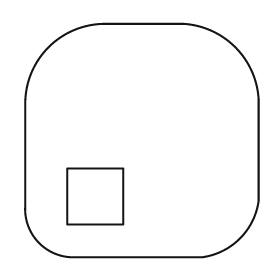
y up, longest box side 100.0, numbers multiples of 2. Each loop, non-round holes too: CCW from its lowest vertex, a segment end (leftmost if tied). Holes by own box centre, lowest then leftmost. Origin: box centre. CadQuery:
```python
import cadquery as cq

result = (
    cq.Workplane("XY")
    .moveTo(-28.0, -50.0)
    .lineTo(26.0, -50.0)
    .threePointArc((42.0, -42.0), (50.0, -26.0))
    .lineTo(50.0, 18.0)
    .threePointArc((40.0, 40.0), (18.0, 50.0))
    .lineTo(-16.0, 50.0)
    .threePointArc((-40.0, 40.0), (-50.0, 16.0))
    .lineTo(-50.0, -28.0)
    .threePointArc((-44.0, -44.0), (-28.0, -50.0))
    .close()
    .moveTo(-32.0, -36.0)
    .lineTo(-8.0, -36.0)
    .lineTo(-8.0, -12.0)
    .lineTo(-32.0, -12.0)
    .close()
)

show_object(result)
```